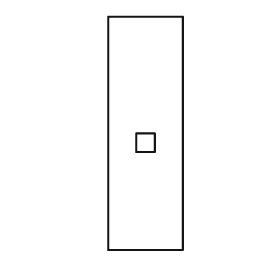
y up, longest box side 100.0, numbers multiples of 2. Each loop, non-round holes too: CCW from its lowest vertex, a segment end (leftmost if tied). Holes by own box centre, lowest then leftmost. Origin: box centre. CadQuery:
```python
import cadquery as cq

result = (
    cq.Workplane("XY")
    .moveTo(-16.0, -50.0)
    .lineTo(16.0, -50.0)
    .lineTo(16.0, 50.0)
    .lineTo(-16.0, 50.0)
    .close()
    .moveTo(-4.0, -8.0)
    .lineTo(4.0, -8.0)
    .lineTo(4.0, 0.0)
    .lineTo(-4.0, 0.0)
    .close()
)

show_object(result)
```